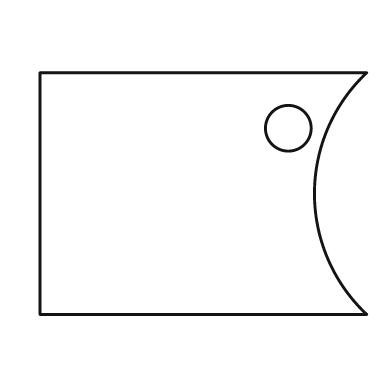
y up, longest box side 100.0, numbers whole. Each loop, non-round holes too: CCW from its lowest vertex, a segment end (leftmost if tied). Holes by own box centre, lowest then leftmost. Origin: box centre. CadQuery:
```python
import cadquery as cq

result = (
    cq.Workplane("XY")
    .moveTo(-50.0, -37.0)
    .lineTo(50.0, -37.0)
    .threePointArc((34.0, 0.0), (50.0, 37.0))
    .lineTo(-50.0, 37.0)
    .close()
    .moveTo(26.0, 20.0)
    .circle(7.0)
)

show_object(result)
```